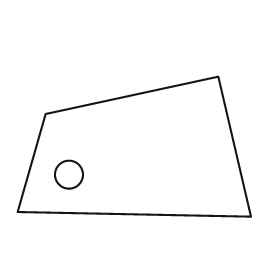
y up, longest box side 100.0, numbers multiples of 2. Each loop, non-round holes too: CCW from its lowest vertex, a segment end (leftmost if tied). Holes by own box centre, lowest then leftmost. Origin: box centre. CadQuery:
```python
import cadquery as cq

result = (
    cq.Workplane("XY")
    .moveTo(50.0, -30.0)
    .lineTo(36.0, 30.0)
    .lineTo(-38.0, 14.0)
    .lineTo(-50.0, -28.0)
    .close()
    .moveTo(-28.0, -12.0)
    .circle(6.0)
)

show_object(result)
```